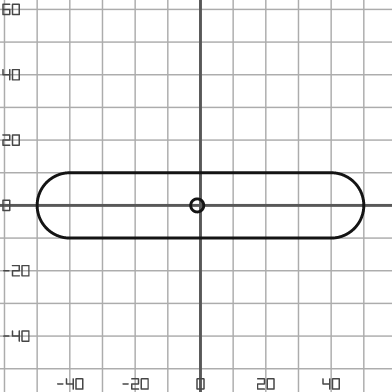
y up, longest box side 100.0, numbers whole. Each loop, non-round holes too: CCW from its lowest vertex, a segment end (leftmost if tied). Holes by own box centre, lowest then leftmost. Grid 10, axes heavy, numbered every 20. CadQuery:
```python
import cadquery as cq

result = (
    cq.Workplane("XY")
    .moveTo(-40.0, -10.0)
    .lineTo(40.0, -10.0)
    .threePointArc((50.0, 0.0), (40.0, 10.0))
    .lineTo(-40.0, 10.0)
    .threePointArc((-50.0, 0.0), (-40.0, -10.0))
    .close()
    .moveTo(-1.0, 0.0)
    .circle(2.0)
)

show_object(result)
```